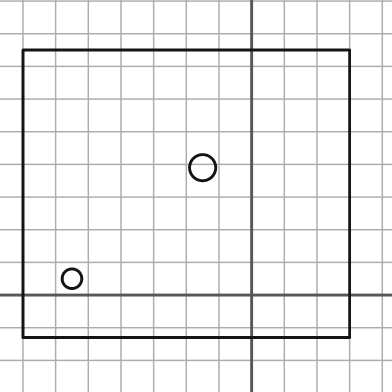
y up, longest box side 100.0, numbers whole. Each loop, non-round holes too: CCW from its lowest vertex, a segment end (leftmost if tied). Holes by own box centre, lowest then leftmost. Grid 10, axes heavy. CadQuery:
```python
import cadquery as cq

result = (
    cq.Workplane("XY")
    .moveTo(-70.0, -13.0)
    .lineTo(30.0, -13.0)
    .lineTo(30.0, 75.0)
    .lineTo(-70.0, 75.0)
    .close()
    .moveTo(-55.0, 5.0)
    .circle(3.0)
    .moveTo(-15.0, 39.0)
    .circle(4.0)
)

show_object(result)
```